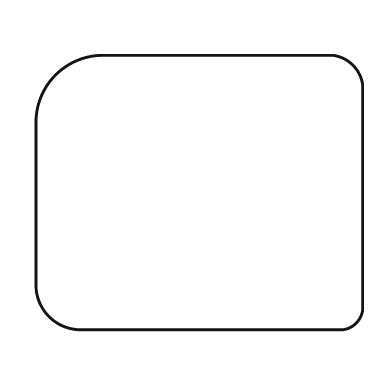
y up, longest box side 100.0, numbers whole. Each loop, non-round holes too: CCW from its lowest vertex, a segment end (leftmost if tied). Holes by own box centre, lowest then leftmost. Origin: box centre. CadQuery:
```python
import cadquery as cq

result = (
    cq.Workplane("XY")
    .moveTo(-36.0, -42.0)
    .lineTo(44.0, -42.0)
    .threePointArc((48.0, -40.0), (50.0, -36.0))
    .lineTo(50.0, 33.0)
    .threePointArc((47.0, 39.0), (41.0, 42.0))
    .lineTo(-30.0, 42.0)
    .threePointArc((-44.0, 36.0), (-50.0, 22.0))
    .lineTo(-50.0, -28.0)
    .threePointArc((-46.0, -38.0), (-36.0, -42.0))
    .close()
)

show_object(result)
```